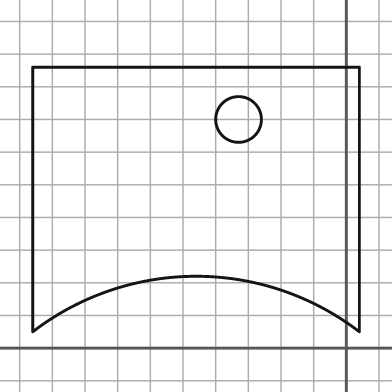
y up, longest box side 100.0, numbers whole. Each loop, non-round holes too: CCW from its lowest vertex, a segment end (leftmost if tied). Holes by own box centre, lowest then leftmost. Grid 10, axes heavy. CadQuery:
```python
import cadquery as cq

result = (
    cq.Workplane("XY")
    .moveTo(-96.0, 5.0)
    .threePointArc((-46.0, 22.0), (4.0, 5.0))
    .lineTo(4.0, 86.0)
    .lineTo(-96.0, 86.0)
    .close()
    .moveTo(-33.0, 70.0)
    .circle(7.0)
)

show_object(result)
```